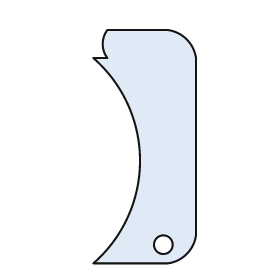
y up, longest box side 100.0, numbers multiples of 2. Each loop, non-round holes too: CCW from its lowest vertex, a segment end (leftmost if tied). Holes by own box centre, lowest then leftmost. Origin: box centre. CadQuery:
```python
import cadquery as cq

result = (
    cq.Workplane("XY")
    .moveTo(-22.0, -50.0)
    .lineTo(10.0, -50.0)
    .threePointArc((18.0, -46.0), (22.0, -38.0))
    .lineTo(22.0, 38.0)
    .threePointArc((18.0, 46.0), (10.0, 50.0))
    .lineTo(-16.0, 50.0)
    .threePointArc((-18.0, 44.0), (-16.0, 38.0))
    .lineTo(-22.0, 38.0)
    .threePointArc((-2.0, -6.0), (-22.0, -50.0))
    .close()
    .moveTo(8.0, -42.0)
    .circle(4.0)
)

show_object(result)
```